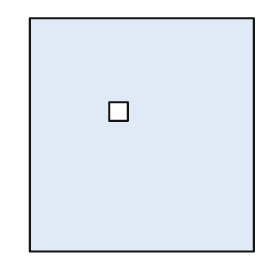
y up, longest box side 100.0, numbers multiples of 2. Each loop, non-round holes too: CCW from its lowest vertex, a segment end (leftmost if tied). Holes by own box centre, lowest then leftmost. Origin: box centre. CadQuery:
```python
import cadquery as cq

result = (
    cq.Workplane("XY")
    .moveTo(-48.0, -50.0)
    .lineTo(48.0, -50.0)
    .lineTo(48.0, 50.0)
    .lineTo(-48.0, 50.0)
    .close()
    .moveTo(-14.0, 6.0)
    .lineTo(-6.0, 6.0)
    .lineTo(-6.0, 14.0)
    .lineTo(-14.0, 14.0)
    .close()
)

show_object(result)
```